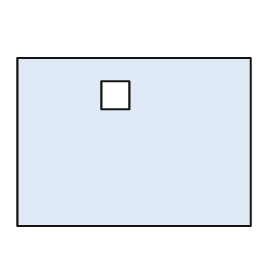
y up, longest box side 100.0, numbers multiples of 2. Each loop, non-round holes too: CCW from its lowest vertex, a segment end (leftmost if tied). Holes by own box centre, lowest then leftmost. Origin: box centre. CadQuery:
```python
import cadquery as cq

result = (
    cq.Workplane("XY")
    .moveTo(-50.0, -36.0)
    .lineTo(50.0, -36.0)
    .lineTo(50.0, 36.0)
    .lineTo(-50.0, 36.0)
    .close()
    .moveTo(-14.0, 14.0)
    .lineTo(-2.0, 14.0)
    .lineTo(-2.0, 26.0)
    .lineTo(-14.0, 26.0)
    .close()
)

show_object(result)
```